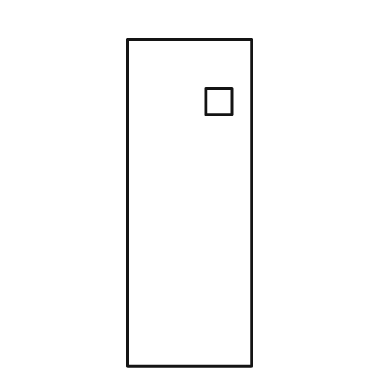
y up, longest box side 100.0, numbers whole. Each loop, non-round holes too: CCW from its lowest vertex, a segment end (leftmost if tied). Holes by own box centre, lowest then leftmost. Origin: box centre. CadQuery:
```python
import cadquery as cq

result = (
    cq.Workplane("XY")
    .moveTo(-19.0, -50.0)
    .lineTo(19.0, -50.0)
    .lineTo(19.0, 50.0)
    .lineTo(-19.0, 50.0)
    .close()
    .moveTo(5.0, 27.0)
    .lineTo(13.0, 27.0)
    .lineTo(13.0, 35.0)
    .lineTo(5.0, 35.0)
    .close()
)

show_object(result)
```